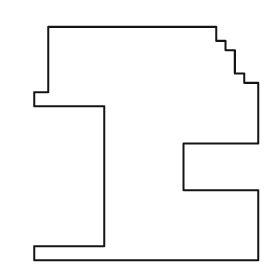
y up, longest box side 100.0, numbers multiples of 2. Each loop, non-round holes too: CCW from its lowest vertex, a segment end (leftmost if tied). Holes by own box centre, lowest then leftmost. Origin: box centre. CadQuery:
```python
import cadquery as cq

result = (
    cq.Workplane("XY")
    .moveTo(-48.0, -50.0)
    .lineTo(48.0, -50.0)
    .lineTo(48.0, -20.0)
    .lineTo(16.0, -20.0)
    .lineTo(16.0, 0.0)
    .lineTo(48.0, 0.0)
    .lineTo(48.0, 26.0)
    .lineTo(42.0, 26.0)
    .lineTo(42.0, 30.0)
    .lineTo(38.0, 30.0)
    .lineTo(38.0, 40.0)
    .lineTo(34.0, 40.0)
    .lineTo(34.0, 44.0)
    .lineTo(30.0, 44.0)
    .lineTo(30.0, 50.0)
    .lineTo(-42.0, 50.0)
    .lineTo(-42.0, 22.0)
    .lineTo(-48.0, 22.0)
    .lineTo(-48.0, 16.0)
    .lineTo(-18.0, 16.0)
    .lineTo(-18.0, -44.0)
    .lineTo(-48.0, -44.0)
    .close()
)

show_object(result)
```